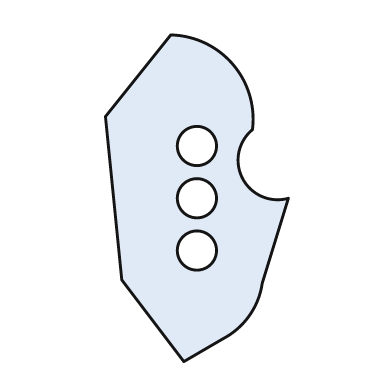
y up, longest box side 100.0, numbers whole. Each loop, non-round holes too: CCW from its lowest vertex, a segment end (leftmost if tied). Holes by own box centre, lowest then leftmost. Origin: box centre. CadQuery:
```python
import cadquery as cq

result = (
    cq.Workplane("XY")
    .moveTo(-4.0, -50.0)
    .lineTo(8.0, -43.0)
    .threePointArc((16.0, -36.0), (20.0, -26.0))
    .lineTo(28.0, 0.0)
    .threePointArc((14.0, 6.0), (17.0, 21.0))
    .threePointArc((11.0, 41.0), (-8.0, 50.0))
    .lineTo(-28.0, 25.0)
    .lineTo(-23.0, -25.0)
    .close()
    .moveTo(0.0, -16.0)
    .circle(6.0)
    .moveTo(0.0, 0.0)
    .circle(6.0)
    .moveTo(0.0, 16.0)
    .circle(6.0)
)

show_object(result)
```